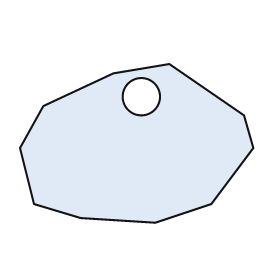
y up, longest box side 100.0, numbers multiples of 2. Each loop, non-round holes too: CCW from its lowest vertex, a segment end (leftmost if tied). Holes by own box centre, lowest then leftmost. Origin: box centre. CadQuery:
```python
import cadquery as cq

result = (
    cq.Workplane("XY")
    .moveTo(8.0, -34.0)
    .lineTo(32.0, -26.0)
    .lineTo(50.0, -2.0)
    .lineTo(46.0, 12.0)
    .lineTo(14.0, 34.0)
    .lineTo(-10.0, 30.0)
    .lineTo(-40.0, 16.0)
    .lineTo(-50.0, -2.0)
    .lineTo(-44.0, -26.0)
    .lineTo(-24.0, -32.0)
    .close()
    .moveTo(2.0, 20.0)
    .circle(8.0)
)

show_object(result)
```